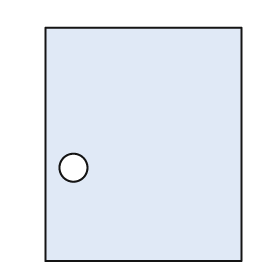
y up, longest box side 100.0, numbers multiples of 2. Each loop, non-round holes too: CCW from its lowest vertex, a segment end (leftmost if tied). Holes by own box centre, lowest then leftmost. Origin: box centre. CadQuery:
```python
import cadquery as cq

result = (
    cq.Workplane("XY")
    .moveTo(-42.0, -50.0)
    .lineTo(42.0, -50.0)
    .lineTo(42.0, 50.0)
    .lineTo(-42.0, 50.0)
    .close()
    .moveTo(-30.0, -10.0)
    .circle(6.0)
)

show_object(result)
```